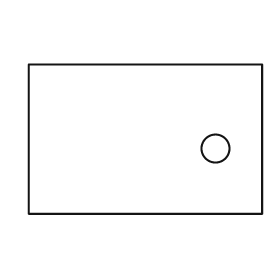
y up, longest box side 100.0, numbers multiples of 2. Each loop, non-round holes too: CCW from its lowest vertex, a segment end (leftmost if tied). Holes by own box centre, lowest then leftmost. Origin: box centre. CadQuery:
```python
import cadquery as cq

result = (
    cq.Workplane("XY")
    .moveTo(-50.0, -32.0)
    .lineTo(50.0, -32.0)
    .lineTo(50.0, 32.0)
    .lineTo(-50.0, 32.0)
    .close()
    .moveTo(30.0, -4.0)
    .circle(6.0)
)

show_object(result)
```